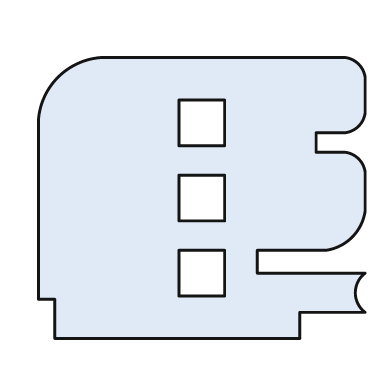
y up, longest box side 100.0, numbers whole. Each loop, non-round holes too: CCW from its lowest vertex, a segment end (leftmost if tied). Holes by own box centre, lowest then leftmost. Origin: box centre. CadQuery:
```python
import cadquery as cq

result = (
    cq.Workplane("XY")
    .moveTo(-45.0, -43.0)
    .lineTo(30.0, -43.0)
    .lineTo(30.0, -35.0)
    .lineTo(50.0, -35.0)
    .threePointArc((47.0, -29.0), (50.0, -23.0))
    .lineTo(17.0, -23.0)
    .lineTo(17.0, -16.0)
    .lineTo(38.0, -16.0)
    .threePointArc((46.0, -12.0), (50.0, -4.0))
    .lineTo(50.0, 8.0)
    .threePointArc((48.0, 12.0), (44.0, 14.0))
    .lineTo(35.0, 14.0)
    .lineTo(35.0, 20.0)
    .lineTo(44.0, 20.0)
    .threePointArc((48.0, 22.0), (50.0, 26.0))
    .lineTo(50.0, 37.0)
    .threePointArc((48.0, 41.0), (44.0, 43.0))
    .lineTo(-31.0, 43.0)
    .threePointArc((-44.0, 37.0), (-50.0, 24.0))
    .lineTo(-50.0, -31.0)
    .lineTo(-45.0, -31.0)
    .close()
    .moveTo(-7.0, -30.0)
    .lineTo(7.0, -30.0)
    .lineTo(7.0, -16.0)
    .lineTo(-7.0, -16.0)
    .close()
    .moveTo(-7.0, -7.0)
    .lineTo(7.0, -7.0)
    .lineTo(7.0, 7.0)
    .lineTo(-7.0, 7.0)
    .close()
    .moveTo(-7.0, 16.0)
    .lineTo(7.0, 16.0)
    .lineTo(7.0, 30.0)
    .lineTo(-7.0, 30.0)
    .close()
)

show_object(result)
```